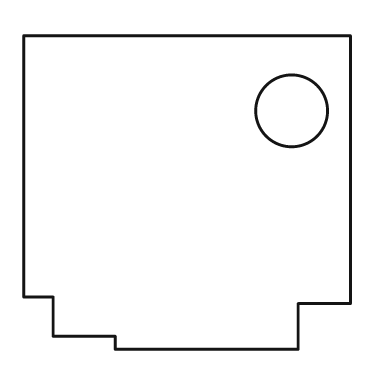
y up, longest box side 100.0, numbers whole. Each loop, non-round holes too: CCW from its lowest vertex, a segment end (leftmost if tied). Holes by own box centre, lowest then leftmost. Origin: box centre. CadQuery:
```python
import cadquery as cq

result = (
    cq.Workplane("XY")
    .moveTo(-22.0, -48.0)
    .lineTo(34.0, -48.0)
    .lineTo(34.0, -34.0)
    .lineTo(50.0, -34.0)
    .lineTo(50.0, 48.0)
    .lineTo(-50.0, 48.0)
    .lineTo(-50.0, -32.0)
    .lineTo(-41.0, -32.0)
    .lineTo(-41.0, -44.0)
    .lineTo(-22.0, -44.0)
    .close()
    .moveTo(32.0, 25.0)
    .circle(11.0)
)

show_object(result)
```